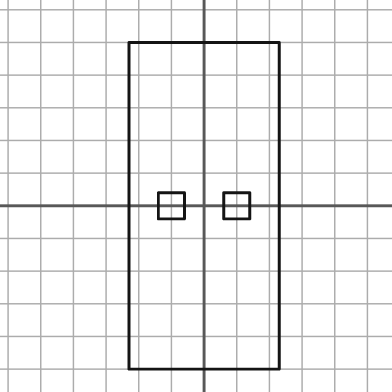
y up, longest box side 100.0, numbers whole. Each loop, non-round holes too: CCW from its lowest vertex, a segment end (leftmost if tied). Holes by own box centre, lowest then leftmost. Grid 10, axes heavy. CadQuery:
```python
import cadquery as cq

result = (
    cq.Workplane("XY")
    .moveTo(-23.0, -50.0)
    .lineTo(23.0, -50.0)
    .lineTo(23.0, 50.0)
    .lineTo(-23.0, 50.0)
    .close()
    .moveTo(-14.0, -4.0)
    .lineTo(-6.0, -4.0)
    .lineTo(-6.0, 4.0)
    .lineTo(-14.0, 4.0)
    .close()
    .moveTo(6.0, -4.0)
    .lineTo(14.0, -4.0)
    .lineTo(14.0, 4.0)
    .lineTo(6.0, 4.0)
    .close()
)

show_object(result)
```